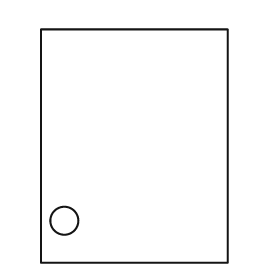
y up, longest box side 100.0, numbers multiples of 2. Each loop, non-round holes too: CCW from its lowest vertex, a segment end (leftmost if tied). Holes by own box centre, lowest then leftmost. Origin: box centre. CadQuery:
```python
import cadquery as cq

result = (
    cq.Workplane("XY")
    .moveTo(-40.0, -50.0)
    .lineTo(40.0, -50.0)
    .lineTo(40.0, 50.0)
    .lineTo(-40.0, 50.0)
    .close()
    .moveTo(-30.0, -32.0)
    .circle(6.0)
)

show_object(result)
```